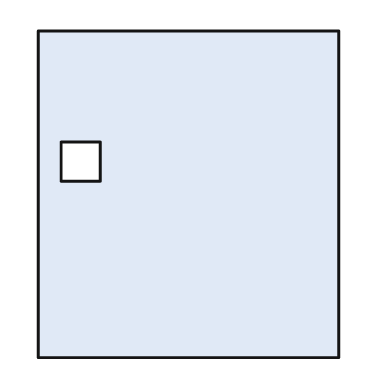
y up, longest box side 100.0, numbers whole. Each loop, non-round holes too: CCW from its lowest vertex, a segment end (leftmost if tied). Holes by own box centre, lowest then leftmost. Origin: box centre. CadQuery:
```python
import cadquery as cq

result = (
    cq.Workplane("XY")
    .moveTo(-46.0, -50.0)
    .lineTo(46.0, -50.0)
    .lineTo(46.0, 50.0)
    .lineTo(-46.0, 50.0)
    .close()
    .moveTo(-39.0, 4.0)
    .lineTo(-27.0, 4.0)
    .lineTo(-27.0, 16.0)
    .lineTo(-39.0, 16.0)
    .close()
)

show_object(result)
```